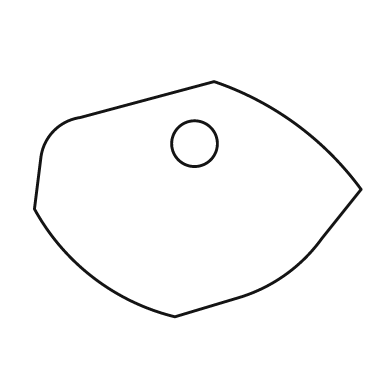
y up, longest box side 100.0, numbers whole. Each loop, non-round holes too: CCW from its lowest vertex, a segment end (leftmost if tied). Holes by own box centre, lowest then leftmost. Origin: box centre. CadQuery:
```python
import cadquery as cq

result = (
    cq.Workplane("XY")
    .moveTo(-7.0, -36.0)
    .lineTo(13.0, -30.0)
    .threePointArc((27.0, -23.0), (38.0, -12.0))
    .lineTo(50.0, 3.0)
    .threePointArc((30.0, 23.0), (5.0, 36.0))
    .lineTo(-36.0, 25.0)
    .threePointArc((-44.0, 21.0), (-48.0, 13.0))
    .lineTo(-50.0, -3.0)
    .threePointArc((-32.0, -24.0), (-7.0, -36.0))
    .close()
    .moveTo(-1.0, 17.0)
    .circle(7.0)
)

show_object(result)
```